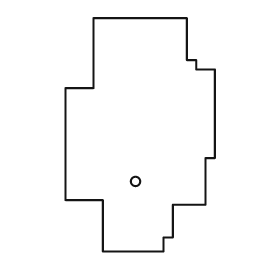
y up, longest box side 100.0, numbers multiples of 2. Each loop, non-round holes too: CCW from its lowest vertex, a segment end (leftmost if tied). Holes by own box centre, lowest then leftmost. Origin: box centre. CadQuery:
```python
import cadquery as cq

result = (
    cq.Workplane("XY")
    .moveTo(-16.0, -50.0)
    .lineTo(10.0, -50.0)
    .lineTo(10.0, -44.0)
    .lineTo(14.0, -44.0)
    .lineTo(14.0, -30.0)
    .lineTo(28.0, -30.0)
    .lineTo(28.0, -10.0)
    .lineTo(32.0, -10.0)
    .lineTo(32.0, 28.0)
    .lineTo(24.0, 28.0)
    .lineTo(24.0, 32.0)
    .lineTo(20.0, 32.0)
    .lineTo(20.0, 50.0)
    .lineTo(-20.0, 50.0)
    .lineTo(-20.0, 20.0)
    .lineTo(-32.0, 20.0)
    .lineTo(-32.0, -28.0)
    .lineTo(-16.0, -28.0)
    .close()
    .moveTo(-2.0, -20.0)
    .circle(2.0)
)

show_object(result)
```